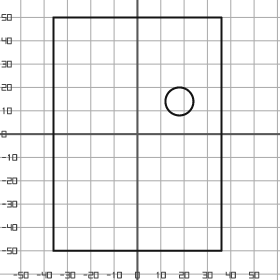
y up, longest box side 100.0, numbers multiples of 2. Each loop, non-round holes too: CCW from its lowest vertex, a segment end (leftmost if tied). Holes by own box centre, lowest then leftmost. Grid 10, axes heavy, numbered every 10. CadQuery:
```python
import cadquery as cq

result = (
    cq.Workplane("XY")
    .moveTo(-36.0, -50.0)
    .lineTo(36.0, -50.0)
    .lineTo(36.0, 50.0)
    .lineTo(-36.0, 50.0)
    .close()
    .moveTo(18.0, 14.0)
    .circle(6.0)
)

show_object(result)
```